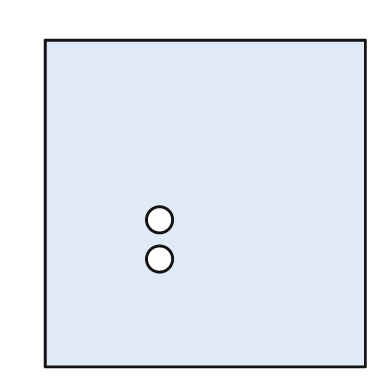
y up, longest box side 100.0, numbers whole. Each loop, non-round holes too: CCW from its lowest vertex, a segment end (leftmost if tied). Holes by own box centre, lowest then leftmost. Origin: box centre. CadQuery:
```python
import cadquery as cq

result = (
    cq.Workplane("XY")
    .moveTo(-49.0, -50.0)
    .lineTo(49.0, -50.0)
    .lineTo(49.0, 50.0)
    .lineTo(-49.0, 50.0)
    .close()
    .moveTo(-14.0, -17.0)
    .circle(4.0)
    .moveTo(-14.0, -5.0)
    .circle(4.0)
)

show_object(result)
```